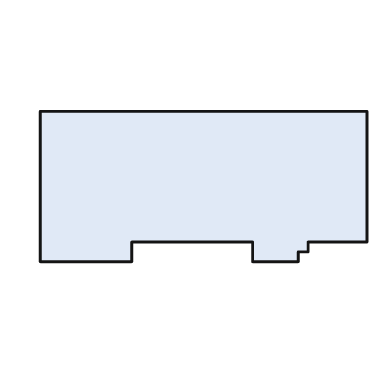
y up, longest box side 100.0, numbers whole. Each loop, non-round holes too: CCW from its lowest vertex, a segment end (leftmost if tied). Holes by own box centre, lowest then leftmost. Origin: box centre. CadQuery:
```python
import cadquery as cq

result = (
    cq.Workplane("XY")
    .moveTo(-50.0, -23.0)
    .lineTo(-22.0, -23.0)
    .lineTo(-22.0, -17.0)
    .lineTo(15.0, -17.0)
    .lineTo(15.0, -23.0)
    .lineTo(29.0, -23.0)
    .lineTo(29.0, -20.0)
    .lineTo(32.0, -20.0)
    .lineTo(32.0, -17.0)
    .lineTo(50.0, -17.0)
    .lineTo(50.0, 23.0)
    .lineTo(-50.0, 23.0)
    .close()
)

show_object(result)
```